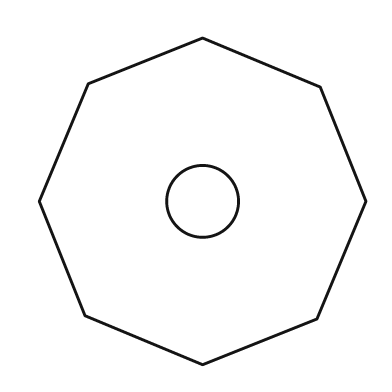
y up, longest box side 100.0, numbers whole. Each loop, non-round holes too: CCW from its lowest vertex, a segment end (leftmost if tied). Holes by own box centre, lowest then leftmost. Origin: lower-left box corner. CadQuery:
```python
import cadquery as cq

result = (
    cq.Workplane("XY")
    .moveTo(50.0, 0.0)
    .lineTo(85.0, 14.0)
    .lineTo(100.0, 50.0)
    .lineTo(86.0, 85.0)
    .lineTo(50.0, 100.0)
    .lineTo(15.0, 86.0)
    .lineTo(0.0, 50.0)
    .lineTo(14.0, 15.0)
    .close()
    .moveTo(50.0, 50.0)
    .circle(11.0)
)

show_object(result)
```